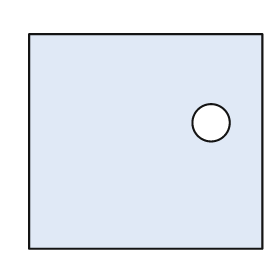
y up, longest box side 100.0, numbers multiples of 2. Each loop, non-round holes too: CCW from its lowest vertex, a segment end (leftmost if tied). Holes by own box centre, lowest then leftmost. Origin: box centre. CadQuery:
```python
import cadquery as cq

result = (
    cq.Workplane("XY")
    .moveTo(-50.0, -46.0)
    .lineTo(50.0, -46.0)
    .lineTo(50.0, 46.0)
    .lineTo(-50.0, 46.0)
    .close()
    .moveTo(28.0, 8.0)
    .circle(8.0)
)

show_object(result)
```